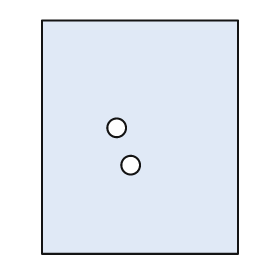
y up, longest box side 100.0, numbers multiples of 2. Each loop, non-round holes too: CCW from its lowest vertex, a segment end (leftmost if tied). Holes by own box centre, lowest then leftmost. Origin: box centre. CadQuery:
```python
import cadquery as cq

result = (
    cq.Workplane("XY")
    .moveTo(-42.0, -50.0)
    .lineTo(42.0, -50.0)
    .lineTo(42.0, 50.0)
    .lineTo(-42.0, 50.0)
    .close()
    .moveTo(-4.0, -12.0)
    .circle(4.0)
    .moveTo(-10.0, 4.0)
    .circle(4.0)
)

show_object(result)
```